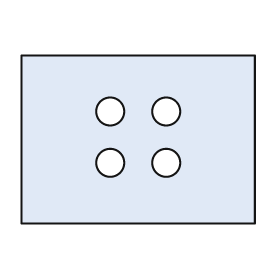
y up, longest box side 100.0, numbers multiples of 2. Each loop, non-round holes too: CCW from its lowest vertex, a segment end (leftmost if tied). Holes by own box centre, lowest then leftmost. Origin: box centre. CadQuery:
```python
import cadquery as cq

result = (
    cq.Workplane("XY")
    .moveTo(-50.0, -36.0)
    .lineTo(50.0, -36.0)
    .lineTo(50.0, 36.0)
    .lineTo(-50.0, 36.0)
    .close()
    .moveTo(-12.0, -10.0)
    .circle(6.0)
    .moveTo(12.0, -10.0)
    .circle(6.0)
    .moveTo(-12.0, 12.0)
    .circle(6.0)
    .moveTo(12.0, 12.0)
    .circle(6.0)
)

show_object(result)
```